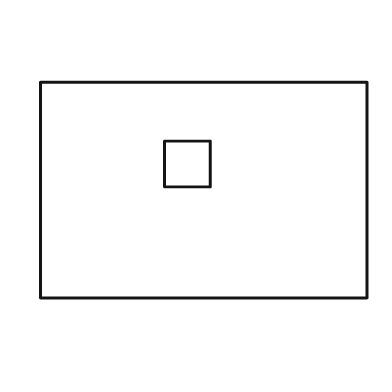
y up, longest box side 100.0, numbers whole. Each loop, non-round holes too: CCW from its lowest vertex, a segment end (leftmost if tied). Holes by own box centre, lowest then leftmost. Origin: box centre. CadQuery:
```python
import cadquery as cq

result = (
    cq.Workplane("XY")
    .moveTo(-50.0, -33.0)
    .lineTo(50.0, -33.0)
    .lineTo(50.0, 33.0)
    .lineTo(-50.0, 33.0)
    .close()
    .moveTo(-12.0, 1.0)
    .lineTo(2.0, 1.0)
    .lineTo(2.0, 15.0)
    .lineTo(-12.0, 15.0)
    .close()
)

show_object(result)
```